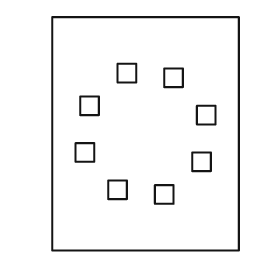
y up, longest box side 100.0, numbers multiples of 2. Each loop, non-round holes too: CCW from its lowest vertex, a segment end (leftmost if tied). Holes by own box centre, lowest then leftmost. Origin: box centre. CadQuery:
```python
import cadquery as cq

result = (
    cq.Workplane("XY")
    .moveTo(-40.0, -50.0)
    .lineTo(40.0, -50.0)
    .lineTo(40.0, 50.0)
    .lineTo(-40.0, 50.0)
    .close()
    .moveTo(4.0, -30.0)
    .lineTo(12.0, -30.0)
    .lineTo(12.0, -22.0)
    .lineTo(4.0, -22.0)
    .close()
    .moveTo(-16.0, -28.0)
    .lineTo(-8.0, -28.0)
    .lineTo(-8.0, -20.0)
    .lineTo(-16.0, -20.0)
    .close()
    .moveTo(20.0, -16.0)
    .lineTo(28.0, -16.0)
    .lineTo(28.0, -8.0)
    .lineTo(20.0, -8.0)
    .close()
    .moveTo(-30.0, -12.0)
    .lineTo(-22.0, -12.0)
    .lineTo(-22.0, -4.0)
    .lineTo(-30.0, -4.0)
    .close()
    .moveTo(22.0, 4.0)
    .lineTo(30.0, 4.0)
    .lineTo(30.0, 12.0)
    .lineTo(22.0, 12.0)
    .close()
    .moveTo(-28.0, 8.0)
    .lineTo(-20.0, 8.0)
    .lineTo(-20.0, 16.0)
    .lineTo(-28.0, 16.0)
    .close()
    .moveTo(8.0, 20.0)
    .lineTo(16.0, 20.0)
    .lineTo(16.0, 28.0)
    .lineTo(8.0, 28.0)
    .close()
    .moveTo(-12.0, 22.0)
    .lineTo(-4.0, 22.0)
    .lineTo(-4.0, 30.0)
    .lineTo(-12.0, 30.0)
    .close()
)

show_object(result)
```